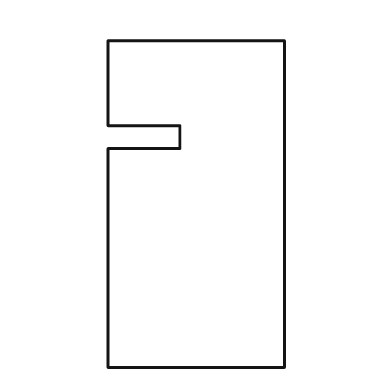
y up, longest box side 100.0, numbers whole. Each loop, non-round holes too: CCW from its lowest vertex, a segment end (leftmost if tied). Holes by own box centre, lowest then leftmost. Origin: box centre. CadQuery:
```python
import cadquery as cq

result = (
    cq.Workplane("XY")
    .moveTo(-27.0, -50.0)
    .lineTo(27.0, -50.0)
    .lineTo(27.0, 50.0)
    .lineTo(-27.0, 50.0)
    .lineTo(-27.0, 24.0)
    .lineTo(-5.0, 24.0)
    .lineTo(-5.0, 17.0)
    .lineTo(-27.0, 17.0)
    .close()
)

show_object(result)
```